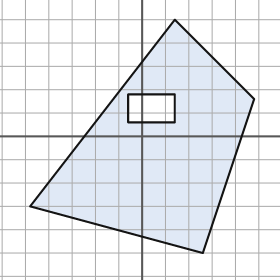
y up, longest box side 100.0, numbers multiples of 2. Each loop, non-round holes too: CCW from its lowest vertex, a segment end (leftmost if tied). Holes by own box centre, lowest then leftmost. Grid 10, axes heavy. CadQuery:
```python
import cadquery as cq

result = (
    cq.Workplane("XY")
    .moveTo(26.0, -50.0)
    .lineTo(48.0, 16.0)
    .lineTo(14.0, 50.0)
    .lineTo(-48.0, -30.0)
    .close()
    .moveTo(-6.0, 6.0)
    .lineTo(14.0, 6.0)
    .lineTo(14.0, 18.0)
    .lineTo(-6.0, 18.0)
    .close()
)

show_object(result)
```